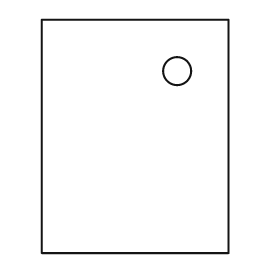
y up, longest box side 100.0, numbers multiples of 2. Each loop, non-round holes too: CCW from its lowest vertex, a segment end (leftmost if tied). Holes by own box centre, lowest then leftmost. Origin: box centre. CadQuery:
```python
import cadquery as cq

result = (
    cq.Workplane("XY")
    .moveTo(-40.0, -50.0)
    .lineTo(40.0, -50.0)
    .lineTo(40.0, 50.0)
    .lineTo(-40.0, 50.0)
    .close()
    .moveTo(18.0, 28.0)
    .circle(6.0)
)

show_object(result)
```